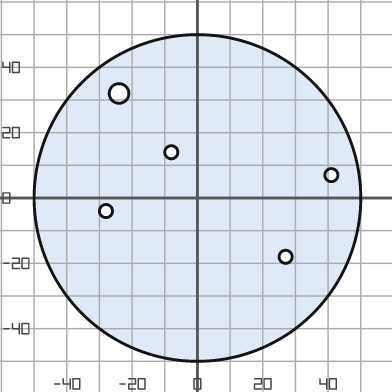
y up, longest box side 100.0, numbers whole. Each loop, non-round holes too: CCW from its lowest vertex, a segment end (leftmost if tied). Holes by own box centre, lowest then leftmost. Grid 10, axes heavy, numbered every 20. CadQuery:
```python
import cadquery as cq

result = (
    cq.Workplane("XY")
    .moveTo(0.0, 0.0)
    .circle(50.0)
    .moveTo(27.0, -18.0)
    .circle(2.0)
    .moveTo(-28.0, -4.0)
    .circle(2.0)
    .moveTo(41.0, 7.0)
    .circle(2.0)
    .moveTo(-8.0, 14.0)
    .circle(2.0)
    .moveTo(-24.0, 32.0)
    .circle(3.0)
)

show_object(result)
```